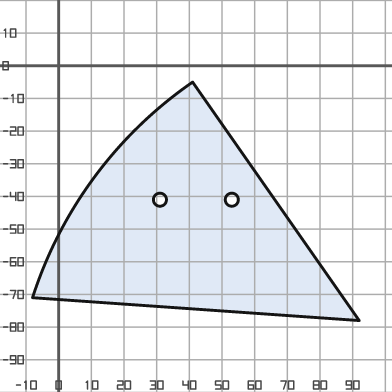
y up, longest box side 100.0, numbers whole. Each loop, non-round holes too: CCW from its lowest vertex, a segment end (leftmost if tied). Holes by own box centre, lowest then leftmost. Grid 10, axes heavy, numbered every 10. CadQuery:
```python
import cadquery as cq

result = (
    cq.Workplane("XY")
    .moveTo(92.0, -78.0)
    .lineTo(41.0, -5.0)
    .threePointArc((11.0, -34.0), (-8.0, -71.0))
    .close()
    .moveTo(31.0, -41.0)
    .circle(2.0)
    .moveTo(53.0, -41.0)
    .circle(2.0)
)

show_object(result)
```